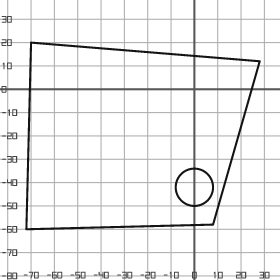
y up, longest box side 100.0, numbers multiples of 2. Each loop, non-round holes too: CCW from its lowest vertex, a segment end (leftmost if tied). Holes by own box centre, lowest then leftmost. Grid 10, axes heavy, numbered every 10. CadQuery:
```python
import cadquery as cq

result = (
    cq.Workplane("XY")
    .moveTo(-72.0, -60.0)
    .lineTo(8.0, -58.0)
    .lineTo(28.0, 12.0)
    .lineTo(-70.0, 20.0)
    .close()
    .moveTo(0.0, -42.0)
    .circle(8.0)
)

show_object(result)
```